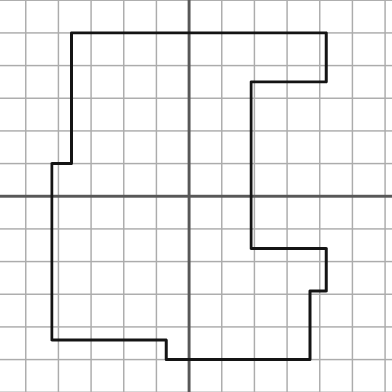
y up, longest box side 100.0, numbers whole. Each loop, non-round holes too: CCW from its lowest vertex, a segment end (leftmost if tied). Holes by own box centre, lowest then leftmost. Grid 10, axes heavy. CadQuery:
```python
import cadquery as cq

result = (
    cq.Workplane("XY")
    .moveTo(-7.0, -50.0)
    .lineTo(37.0, -50.0)
    .lineTo(37.0, -29.0)
    .lineTo(42.0, -29.0)
    .lineTo(42.0, -16.0)
    .lineTo(19.0, -16.0)
    .lineTo(19.0, 35.0)
    .lineTo(42.0, 35.0)
    .lineTo(42.0, 50.0)
    .lineTo(-36.0, 50.0)
    .lineTo(-36.0, 10.0)
    .lineTo(-42.0, 10.0)
    .lineTo(-42.0, -44.0)
    .lineTo(-7.0, -44.0)
    .close()
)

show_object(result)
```